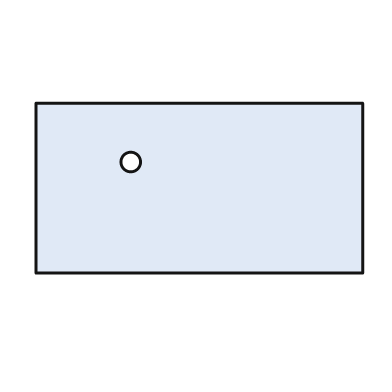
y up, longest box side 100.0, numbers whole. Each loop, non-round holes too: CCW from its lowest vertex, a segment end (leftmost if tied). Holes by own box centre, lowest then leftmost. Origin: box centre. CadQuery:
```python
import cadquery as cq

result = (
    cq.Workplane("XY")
    .moveTo(-50.0, -26.0)
    .lineTo(50.0, -26.0)
    .lineTo(50.0, 26.0)
    .lineTo(-50.0, 26.0)
    .close()
    .moveTo(-21.0, 8.0)
    .circle(3.0)
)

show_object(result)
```